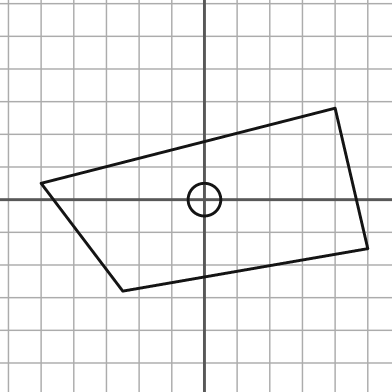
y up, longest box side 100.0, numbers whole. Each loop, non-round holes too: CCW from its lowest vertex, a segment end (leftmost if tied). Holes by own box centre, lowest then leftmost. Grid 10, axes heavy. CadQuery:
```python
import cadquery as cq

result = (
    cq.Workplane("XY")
    .moveTo(-25.0, -28.0)
    .lineTo(50.0, -15.0)
    .lineTo(40.0, 28.0)
    .lineTo(-50.0, 5.0)
    .close()
    .moveTo(0.0, 0.0)
    .circle(5.0)
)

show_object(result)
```